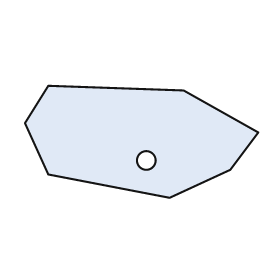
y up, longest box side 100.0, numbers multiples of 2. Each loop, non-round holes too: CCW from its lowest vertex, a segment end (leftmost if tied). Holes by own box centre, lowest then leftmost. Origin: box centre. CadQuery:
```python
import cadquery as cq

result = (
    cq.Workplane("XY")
    .moveTo(12.0, -24.0)
    .lineTo(38.0, -12.0)
    .lineTo(50.0, 4.0)
    .lineTo(18.0, 22.0)
    .lineTo(-40.0, 24.0)
    .lineTo(-50.0, 8.0)
    .lineTo(-40.0, -14.0)
    .close()
    .moveTo(2.0, -8.0)
    .circle(4.0)
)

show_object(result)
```